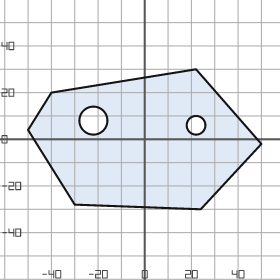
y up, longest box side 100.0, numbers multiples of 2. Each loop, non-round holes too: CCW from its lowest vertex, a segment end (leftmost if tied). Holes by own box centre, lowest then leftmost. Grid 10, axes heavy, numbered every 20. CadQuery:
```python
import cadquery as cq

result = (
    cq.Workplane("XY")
    .moveTo(24.0, -30.0)
    .lineTo(50.0, -2.0)
    .lineTo(22.0, 30.0)
    .lineTo(-40.0, 20.0)
    .lineTo(-50.0, 4.0)
    .lineTo(-30.0, -28.0)
    .close()
    .moveTo(22.0, 6.0)
    .circle(4.0)
    .moveTo(-22.0, 8.0)
    .circle(6.0)
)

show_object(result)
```